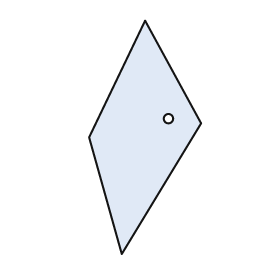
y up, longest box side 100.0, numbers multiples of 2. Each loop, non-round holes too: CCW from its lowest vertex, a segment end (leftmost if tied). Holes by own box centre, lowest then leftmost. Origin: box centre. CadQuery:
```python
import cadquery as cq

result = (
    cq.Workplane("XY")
    .moveTo(-10.0, -50.0)
    .lineTo(24.0, 6.0)
    .lineTo(0.0, 50.0)
    .lineTo(-24.0, 0.0)
    .close()
    .moveTo(10.0, 8.0)
    .circle(2.0)
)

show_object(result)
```